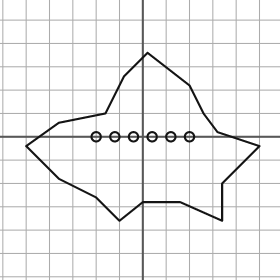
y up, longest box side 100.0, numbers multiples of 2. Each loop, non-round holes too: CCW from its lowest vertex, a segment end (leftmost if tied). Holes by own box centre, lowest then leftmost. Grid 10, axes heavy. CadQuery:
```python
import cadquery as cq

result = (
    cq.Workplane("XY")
    .moveTo(-10.0, -36.0)
    .lineTo(0.0, -28.0)
    .lineTo(16.0, -28.0)
    .lineTo(34.0, -36.0)
    .lineTo(34.0, -20.0)
    .lineTo(50.0, -4.0)
    .lineTo(32.0, 2.0)
    .lineTo(26.0, 10.0)
    .lineTo(20.0, 22.0)
    .lineTo(2.0, 36.0)
    .lineTo(-8.0, 26.0)
    .lineTo(-16.0, 10.0)
    .lineTo(-36.0, 6.0)
    .lineTo(-50.0, -4.0)
    .lineTo(-36.0, -18.0)
    .lineTo(-20.0, -26.0)
    .close()
    .moveTo(-20.0, 0.0)
    .circle(2.0)
    .moveTo(-12.0, 0.0)
    .circle(2.0)
    .moveTo(-4.0, 0.0)
    .circle(2.0)
    .moveTo(4.0, 0.0)
    .circle(2.0)
    .moveTo(12.0, 0.0)
    .circle(2.0)
    .moveTo(20.0, 0.0)
    .circle(2.0)
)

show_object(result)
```